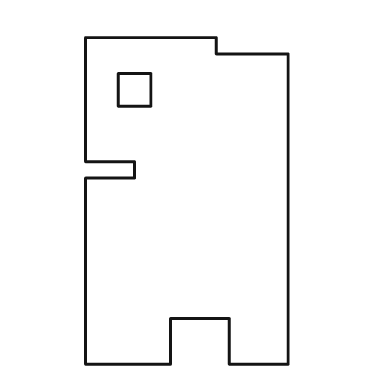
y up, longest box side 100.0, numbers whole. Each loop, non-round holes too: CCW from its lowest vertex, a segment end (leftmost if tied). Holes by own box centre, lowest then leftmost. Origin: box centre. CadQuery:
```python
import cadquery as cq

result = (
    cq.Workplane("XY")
    .moveTo(-31.0, -50.0)
    .lineTo(-5.0, -50.0)
    .lineTo(-5.0, -36.0)
    .lineTo(13.0, -36.0)
    .lineTo(13.0, -50.0)
    .lineTo(31.0, -50.0)
    .lineTo(31.0, 45.0)
    .lineTo(9.0, 45.0)
    .lineTo(9.0, 50.0)
    .lineTo(-31.0, 50.0)
    .lineTo(-31.0, 12.0)
    .lineTo(-16.0, 12.0)
    .lineTo(-16.0, 7.0)
    .lineTo(-31.0, 7.0)
    .close()
    .moveTo(-21.0, 29.0)
    .lineTo(-11.0, 29.0)
    .lineTo(-11.0, 39.0)
    .lineTo(-21.0, 39.0)
    .close()
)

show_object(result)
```